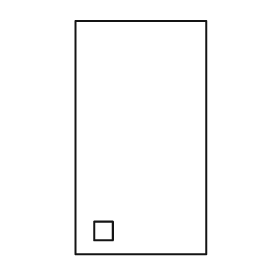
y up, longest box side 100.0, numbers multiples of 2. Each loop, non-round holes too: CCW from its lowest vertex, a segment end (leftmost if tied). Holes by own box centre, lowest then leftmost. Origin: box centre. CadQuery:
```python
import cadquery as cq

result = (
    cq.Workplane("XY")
    .moveTo(-28.0, -50.0)
    .lineTo(28.0, -50.0)
    .lineTo(28.0, 50.0)
    .lineTo(-28.0, 50.0)
    .close()
    .moveTo(-20.0, -44.0)
    .lineTo(-12.0, -44.0)
    .lineTo(-12.0, -36.0)
    .lineTo(-20.0, -36.0)
    .close()
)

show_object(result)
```